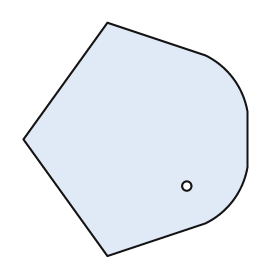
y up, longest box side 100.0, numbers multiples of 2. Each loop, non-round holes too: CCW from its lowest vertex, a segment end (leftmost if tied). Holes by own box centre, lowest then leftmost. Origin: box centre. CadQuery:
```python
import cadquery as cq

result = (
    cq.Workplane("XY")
    .moveTo(-12.0, -50.0)
    .lineTo(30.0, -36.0)
    .threePointArc((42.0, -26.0), (48.0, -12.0))
    .lineTo(48.0, 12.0)
    .threePointArc((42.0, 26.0), (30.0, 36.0))
    .lineTo(-12.0, 50.0)
    .lineTo(-48.0, 0.0)
    .close()
    .moveTo(22.0, -20.0)
    .circle(2.0)
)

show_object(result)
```